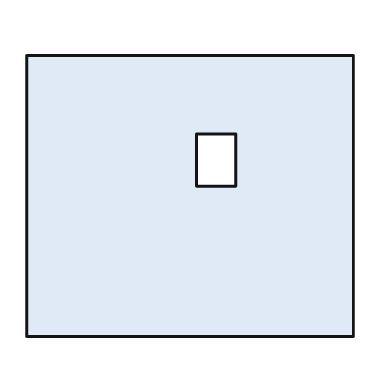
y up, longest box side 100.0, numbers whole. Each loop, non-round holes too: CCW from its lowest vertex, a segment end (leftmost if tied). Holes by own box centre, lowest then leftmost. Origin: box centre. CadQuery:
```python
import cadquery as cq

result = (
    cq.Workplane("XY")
    .moveTo(-50.0, -43.0)
    .lineTo(50.0, -43.0)
    .lineTo(50.0, 43.0)
    .lineTo(-50.0, 43.0)
    .close()
    .moveTo(2.0, 3.0)
    .lineTo(14.0, 3.0)
    .lineTo(14.0, 19.0)
    .lineTo(2.0, 19.0)
    .close()
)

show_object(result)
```